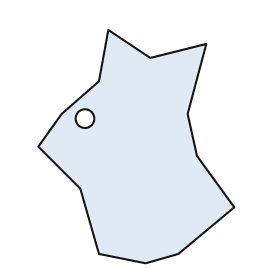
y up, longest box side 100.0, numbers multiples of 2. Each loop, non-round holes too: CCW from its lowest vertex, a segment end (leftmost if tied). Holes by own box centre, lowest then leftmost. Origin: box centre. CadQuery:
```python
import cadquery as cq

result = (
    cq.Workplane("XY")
    .moveTo(4.0, -50.0)
    .lineTo(18.0, -46.0)
    .lineTo(42.0, -26.0)
    .lineTo(26.0, -4.0)
    .lineTo(22.0, 14.0)
    .lineTo(30.0, 44.0)
    .lineTo(6.0, 38.0)
    .lineTo(-12.0, 50.0)
    .lineTo(-16.0, 28.0)
    .lineTo(-32.0, 14.0)
    .lineTo(-42.0, 0.0)
    .lineTo(-24.0, -18.0)
    .lineTo(-16.0, -46.0)
    .close()
    .moveTo(-22.0, 12.0)
    .circle(4.0)
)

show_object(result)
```